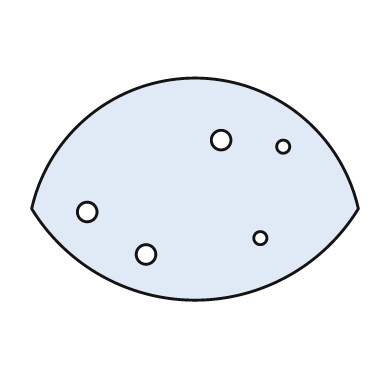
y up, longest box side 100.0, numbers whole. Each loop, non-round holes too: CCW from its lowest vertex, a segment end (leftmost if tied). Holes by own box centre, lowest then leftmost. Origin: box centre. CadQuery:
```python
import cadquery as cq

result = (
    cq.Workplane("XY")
    .moveTo(-50.0, -6.0)
    .threePointArc((0.0, -34.0), (50.0, -6.0))
    .threePointArc((0.0, 34.0), (-50.0, -6.0))
    .close()
    .moveTo(-15.0, -20.0)
    .circle(3.0)
    .moveTo(20.0, -15.0)
    .circle(2.0)
    .moveTo(-33.0, -7.0)
    .circle(3.0)
    .moveTo(27.0, 13.0)
    .circle(2.0)
    .moveTo(8.0, 15.0)
    .circle(3.0)
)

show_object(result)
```